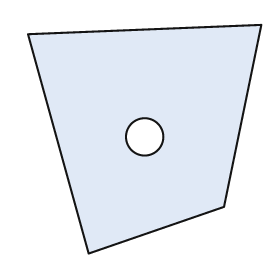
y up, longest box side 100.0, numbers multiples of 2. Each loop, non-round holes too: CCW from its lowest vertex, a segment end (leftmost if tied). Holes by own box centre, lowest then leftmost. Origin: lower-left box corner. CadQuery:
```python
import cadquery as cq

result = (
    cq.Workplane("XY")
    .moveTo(26.0, 0.0)
    .lineTo(84.0, 20.0)
    .lineTo(100.0, 98.0)
    .lineTo(0.0, 94.0)
    .close()
    .moveTo(50.0, 50.0)
    .circle(8.0)
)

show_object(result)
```